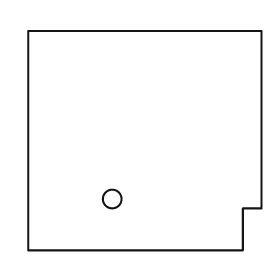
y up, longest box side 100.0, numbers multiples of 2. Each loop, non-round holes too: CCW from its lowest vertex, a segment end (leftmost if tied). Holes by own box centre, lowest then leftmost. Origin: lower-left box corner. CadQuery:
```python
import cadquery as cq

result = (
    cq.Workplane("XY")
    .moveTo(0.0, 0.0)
    .lineTo(92.0, 0.0)
    .lineTo(92.0, 18.0)
    .lineTo(100.0, 18.0)
    .lineTo(100.0, 94.0)
    .lineTo(0.0, 94.0)
    .close()
    .moveTo(36.0, 22.0)
    .circle(4.0)
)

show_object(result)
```